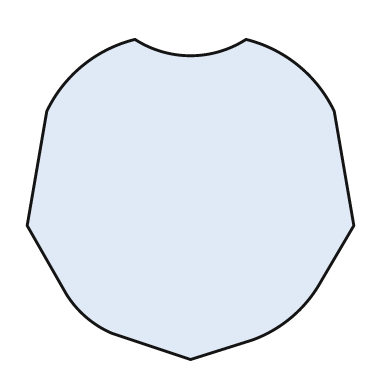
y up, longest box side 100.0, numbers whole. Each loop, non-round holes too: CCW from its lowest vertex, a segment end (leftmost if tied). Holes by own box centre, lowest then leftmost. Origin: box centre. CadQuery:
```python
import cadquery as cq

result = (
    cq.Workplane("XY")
    .moveTo(0.0, -49.0)
    .lineTo(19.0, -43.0)
    .threePointArc((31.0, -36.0), (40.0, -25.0))
    .lineTo(50.0, -8.0)
    .lineTo(44.0, 27.0)
    .threePointArc((33.0, 41.0), (17.0, 49.0))
    .threePointArc((0.0, 44.0), (-17.0, 49.0))
    .threePointArc((-33.0, 41.0), (-44.0, 27.0))
    .lineTo(-50.0, -8.0)
    .lineTo(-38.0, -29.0)
    .threePointArc((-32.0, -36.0), (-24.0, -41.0))
    .close()
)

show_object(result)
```